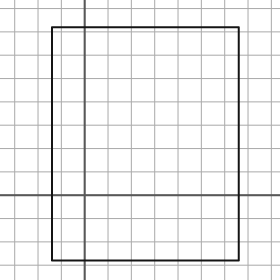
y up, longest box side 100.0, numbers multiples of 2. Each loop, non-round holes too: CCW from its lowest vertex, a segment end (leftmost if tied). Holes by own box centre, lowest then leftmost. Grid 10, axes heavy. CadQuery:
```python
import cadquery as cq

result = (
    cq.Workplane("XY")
    .moveTo(-14.0, -28.0)
    .lineTo(66.0, -28.0)
    .lineTo(66.0, 72.0)
    .lineTo(-14.0, 72.0)
    .close()
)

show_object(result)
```